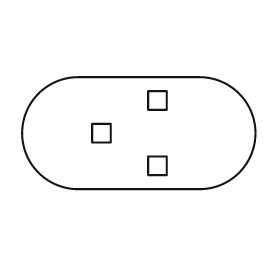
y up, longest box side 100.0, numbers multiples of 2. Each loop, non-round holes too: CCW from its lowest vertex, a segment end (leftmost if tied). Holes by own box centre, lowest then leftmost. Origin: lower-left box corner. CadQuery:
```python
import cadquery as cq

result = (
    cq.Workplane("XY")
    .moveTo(24.0, 0.0)
    .lineTo(76.0, 0.0)
    .threePointArc((100.0, 24.0), (76.0, 48.0))
    .lineTo(24.0, 48.0)
    .threePointArc((0.0, 24.0), (24.0, 0.0))
    .close()
    .moveTo(54.0, 6.0)
    .lineTo(62.0, 6.0)
    .lineTo(62.0, 14.0)
    .lineTo(54.0, 14.0)
    .close()
    .moveTo(30.0, 20.0)
    .lineTo(38.0, 20.0)
    .lineTo(38.0, 28.0)
    .lineTo(30.0, 28.0)
    .close()
    .moveTo(54.0, 34.0)
    .lineTo(62.0, 34.0)
    .lineTo(62.0, 42.0)
    .lineTo(54.0, 42.0)
    .close()
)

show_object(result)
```